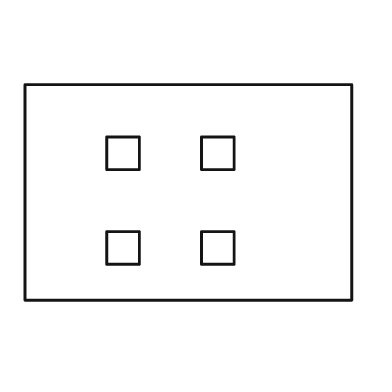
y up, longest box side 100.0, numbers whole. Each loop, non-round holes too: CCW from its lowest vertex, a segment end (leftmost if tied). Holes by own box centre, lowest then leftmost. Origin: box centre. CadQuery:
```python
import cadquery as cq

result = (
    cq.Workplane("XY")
    .moveTo(-50.0, -33.0)
    .lineTo(50.0, -33.0)
    .lineTo(50.0, 33.0)
    .lineTo(-50.0, 33.0)
    .close()
    .moveTo(-25.0, -22.0)
    .lineTo(-15.0, -22.0)
    .lineTo(-15.0, -12.0)
    .lineTo(-25.0, -12.0)
    .close()
    .moveTo(4.0, -22.0)
    .lineTo(14.0, -22.0)
    .lineTo(14.0, -12.0)
    .lineTo(4.0, -12.0)
    .close()
    .moveTo(-25.0, 7.0)
    .lineTo(-15.0, 7.0)
    .lineTo(-15.0, 17.0)
    .lineTo(-25.0, 17.0)
    .close()
    .moveTo(4.0, 7.0)
    .lineTo(14.0, 7.0)
    .lineTo(14.0, 17.0)
    .lineTo(4.0, 17.0)
    .close()
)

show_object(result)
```